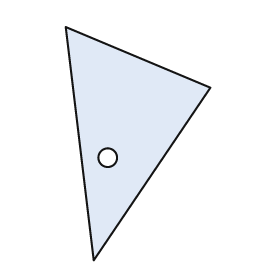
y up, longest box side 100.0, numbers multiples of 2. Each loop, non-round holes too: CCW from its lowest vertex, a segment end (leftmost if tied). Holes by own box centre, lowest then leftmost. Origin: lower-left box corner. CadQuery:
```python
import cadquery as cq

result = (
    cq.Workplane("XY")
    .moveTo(12.0, 0.0)
    .lineTo(62.0, 74.0)
    .lineTo(0.0, 100.0)
    .close()
    .moveTo(18.0, 44.0)
    .circle(4.0)
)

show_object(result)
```